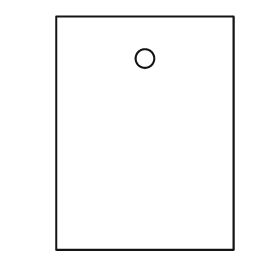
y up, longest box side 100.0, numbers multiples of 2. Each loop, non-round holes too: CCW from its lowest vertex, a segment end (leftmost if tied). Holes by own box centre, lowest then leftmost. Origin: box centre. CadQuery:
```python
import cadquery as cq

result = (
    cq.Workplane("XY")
    .moveTo(-38.0, -50.0)
    .lineTo(38.0, -50.0)
    .lineTo(38.0, 50.0)
    .lineTo(-38.0, 50.0)
    .close()
    .moveTo(0.0, 32.0)
    .circle(4.0)
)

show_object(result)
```